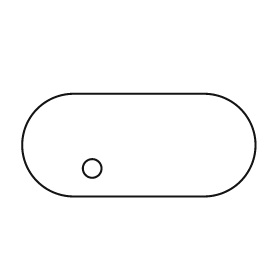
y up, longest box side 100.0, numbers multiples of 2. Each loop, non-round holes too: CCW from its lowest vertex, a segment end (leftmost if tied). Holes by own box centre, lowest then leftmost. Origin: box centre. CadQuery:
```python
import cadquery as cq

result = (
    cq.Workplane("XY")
    .moveTo(-28.0, -22.0)
    .lineTo(28.0, -22.0)
    .threePointArc((50.0, 0.0), (28.0, 22.0))
    .lineTo(-28.0, 22.0)
    .threePointArc((-50.0, 0.0), (-28.0, -22.0))
    .close()
    .moveTo(-20.0, -10.0)
    .circle(4.0)
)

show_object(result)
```